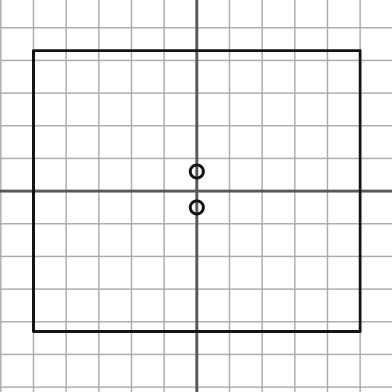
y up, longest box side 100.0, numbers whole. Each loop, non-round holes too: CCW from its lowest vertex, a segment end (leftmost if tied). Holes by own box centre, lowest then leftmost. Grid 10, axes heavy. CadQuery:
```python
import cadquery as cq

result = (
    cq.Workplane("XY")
    .moveTo(-50.0, -43.0)
    .lineTo(50.0, -43.0)
    .lineTo(50.0, 43.0)
    .lineTo(-50.0, 43.0)
    .close()
    .moveTo(0.0, -5.0)
    .circle(2.0)
    .moveTo(0.0, 6.0)
    .circle(2.0)
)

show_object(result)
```